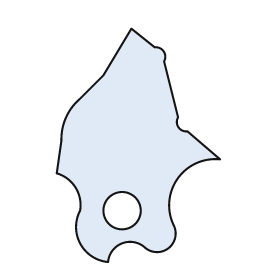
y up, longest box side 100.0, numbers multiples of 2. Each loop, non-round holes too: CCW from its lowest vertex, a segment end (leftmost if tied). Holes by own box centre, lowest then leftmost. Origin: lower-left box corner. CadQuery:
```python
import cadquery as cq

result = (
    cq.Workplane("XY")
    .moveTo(22.0, 0.0)
    .threePointArc((28.0, 8.0), (38.0, 6.0))
    .threePointArc((48.0, 6.0), (50.0, 16.0))
    .threePointArc((52.0, 36.0), (70.0, 44.0))
    .lineTo(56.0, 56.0)
    .threePointArc((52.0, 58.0), (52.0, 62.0))
    .lineTo(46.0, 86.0)
    .threePointArc((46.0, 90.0), (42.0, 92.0))
    .lineTo(32.0, 100.0)
    .lineTo(20.0, 80.0)
    .lineTo(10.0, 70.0)
    .threePointArc((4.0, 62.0), (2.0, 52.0))
    .lineTo(0.0, 38.0)
    .threePointArc((8.0, 32.0), (10.0, 22.0))
    .threePointArc((10.0, 8.0), (22.0, 0.0))
    .close()
    .moveTo(28.0, 22.0)
    .circle(8.0)
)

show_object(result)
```